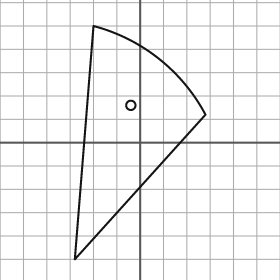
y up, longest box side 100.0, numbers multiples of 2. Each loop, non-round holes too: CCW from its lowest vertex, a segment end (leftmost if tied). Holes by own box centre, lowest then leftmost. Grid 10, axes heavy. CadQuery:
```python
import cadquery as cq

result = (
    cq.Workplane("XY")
    .moveTo(-28.0, -50.0)
    .lineTo(28.0, 12.0)
    .threePointArc((8.0, 36.0), (-20.0, 50.0))
    .close()
    .moveTo(-4.0, 16.0)
    .circle(2.0)
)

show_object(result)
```